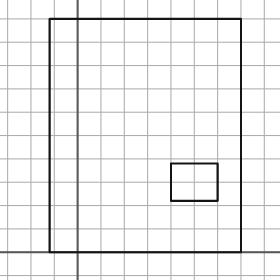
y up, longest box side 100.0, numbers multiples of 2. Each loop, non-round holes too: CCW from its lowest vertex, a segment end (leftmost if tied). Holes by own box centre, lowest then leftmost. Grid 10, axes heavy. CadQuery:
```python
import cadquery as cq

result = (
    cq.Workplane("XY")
    .moveTo(-12.0, 0.0)
    .lineTo(70.0, 0.0)
    .lineTo(70.0, 100.0)
    .lineTo(-12.0, 100.0)
    .close()
    .moveTo(40.0, 22.0)
    .lineTo(60.0, 22.0)
    .lineTo(60.0, 38.0)
    .lineTo(40.0, 38.0)
    .close()
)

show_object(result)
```